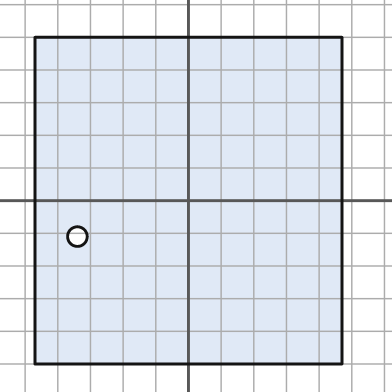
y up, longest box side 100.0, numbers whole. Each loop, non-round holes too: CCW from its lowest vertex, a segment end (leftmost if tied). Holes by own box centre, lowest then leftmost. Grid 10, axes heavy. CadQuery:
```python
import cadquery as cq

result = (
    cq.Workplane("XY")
    .moveTo(-47.0, -50.0)
    .lineTo(47.0, -50.0)
    .lineTo(47.0, 50.0)
    .lineTo(-47.0, 50.0)
    .close()
    .moveTo(-34.0, -11.0)
    .circle(3.0)
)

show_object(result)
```